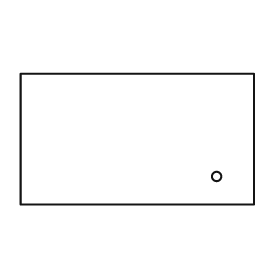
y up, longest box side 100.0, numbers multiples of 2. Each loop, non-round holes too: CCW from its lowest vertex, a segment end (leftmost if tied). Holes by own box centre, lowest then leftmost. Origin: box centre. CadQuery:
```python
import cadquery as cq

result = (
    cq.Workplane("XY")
    .moveTo(-50.0, -28.0)
    .lineTo(50.0, -28.0)
    .lineTo(50.0, 28.0)
    .lineTo(-50.0, 28.0)
    .close()
    .moveTo(34.0, -16.0)
    .circle(2.0)
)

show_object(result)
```